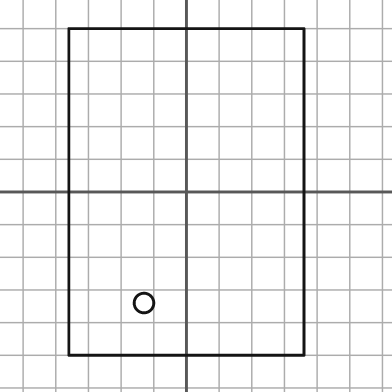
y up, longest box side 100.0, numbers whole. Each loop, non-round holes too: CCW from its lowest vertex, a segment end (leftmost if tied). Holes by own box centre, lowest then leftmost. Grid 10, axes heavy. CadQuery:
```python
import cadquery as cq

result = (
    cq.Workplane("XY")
    .moveTo(-36.0, -50.0)
    .lineTo(36.0, -50.0)
    .lineTo(36.0, 50.0)
    .lineTo(-36.0, 50.0)
    .close()
    .moveTo(-13.0, -34.0)
    .circle(3.0)
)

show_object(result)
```